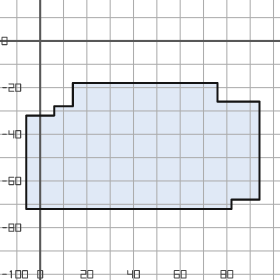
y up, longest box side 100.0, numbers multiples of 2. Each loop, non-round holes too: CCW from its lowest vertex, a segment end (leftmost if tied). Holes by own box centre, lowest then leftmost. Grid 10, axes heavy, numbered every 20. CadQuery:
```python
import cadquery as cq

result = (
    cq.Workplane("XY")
    .moveTo(-6.0, -72.0)
    .lineTo(82.0, -72.0)
    .lineTo(82.0, -68.0)
    .lineTo(94.0, -68.0)
    .lineTo(94.0, -26.0)
    .lineTo(76.0, -26.0)
    .lineTo(76.0, -18.0)
    .lineTo(14.0, -18.0)
    .lineTo(14.0, -28.0)
    .lineTo(6.0, -28.0)
    .lineTo(6.0, -32.0)
    .lineTo(-6.0, -32.0)
    .close()
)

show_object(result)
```